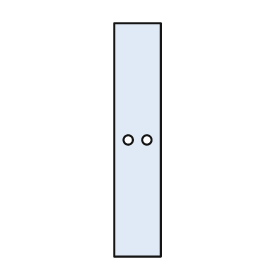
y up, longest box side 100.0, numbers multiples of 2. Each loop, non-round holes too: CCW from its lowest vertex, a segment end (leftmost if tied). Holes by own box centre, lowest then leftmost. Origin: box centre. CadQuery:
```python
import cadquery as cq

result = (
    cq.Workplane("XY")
    .moveTo(-10.0, -50.0)
    .lineTo(10.0, -50.0)
    .lineTo(10.0, 50.0)
    .lineTo(-10.0, 50.0)
    .close()
    .moveTo(-4.0, 0.0)
    .circle(2.0)
    .moveTo(4.0, 0.0)
    .circle(2.0)
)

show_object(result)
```